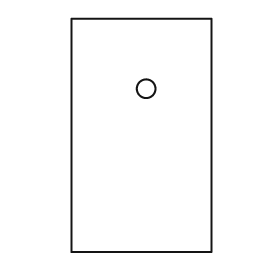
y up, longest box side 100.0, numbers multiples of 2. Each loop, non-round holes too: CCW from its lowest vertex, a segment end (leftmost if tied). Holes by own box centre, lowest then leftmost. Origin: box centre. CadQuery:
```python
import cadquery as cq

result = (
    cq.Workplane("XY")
    .moveTo(-30.0, -50.0)
    .lineTo(30.0, -50.0)
    .lineTo(30.0, 50.0)
    .lineTo(-30.0, 50.0)
    .close()
    .moveTo(2.0, 20.0)
    .circle(4.0)
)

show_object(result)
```